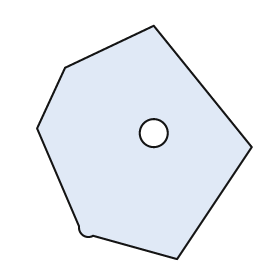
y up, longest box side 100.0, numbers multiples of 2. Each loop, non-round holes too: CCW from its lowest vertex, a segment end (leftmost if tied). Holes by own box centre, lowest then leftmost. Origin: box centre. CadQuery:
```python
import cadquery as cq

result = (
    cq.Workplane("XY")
    .moveTo(14.0, -50.0)
    .lineTo(46.0, -2.0)
    .lineTo(4.0, 50.0)
    .lineTo(-34.0, 32.0)
    .lineTo(-46.0, 6.0)
    .lineTo(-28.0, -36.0)
    .threePointArc((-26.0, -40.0), (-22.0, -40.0))
    .close()
    .moveTo(4.0, 4.0)
    .circle(6.0)
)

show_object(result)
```